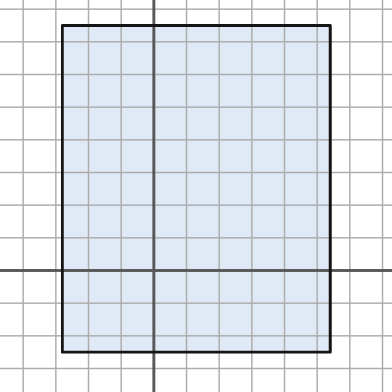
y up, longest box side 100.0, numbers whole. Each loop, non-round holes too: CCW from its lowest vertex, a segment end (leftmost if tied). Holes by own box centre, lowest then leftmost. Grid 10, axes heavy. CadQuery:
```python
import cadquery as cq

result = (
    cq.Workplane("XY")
    .moveTo(-28.0, -25.0)
    .lineTo(54.0, -25.0)
    .lineTo(54.0, 75.0)
    .lineTo(-28.0, 75.0)
    .close()
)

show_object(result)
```